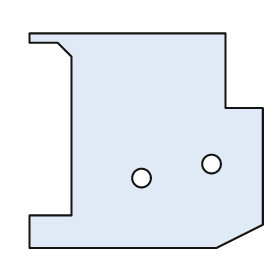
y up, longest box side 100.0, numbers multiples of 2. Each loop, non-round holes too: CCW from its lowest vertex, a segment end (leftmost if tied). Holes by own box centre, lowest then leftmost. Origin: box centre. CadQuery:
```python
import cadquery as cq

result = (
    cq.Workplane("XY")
    .moveTo(-50.0, -46.0)
    .lineTo(30.0, -46.0)
    .lineTo(50.0, -36.0)
    .lineTo(50.0, 14.0)
    .lineTo(34.0, 14.0)
    .lineTo(34.0, 46.0)
    .lineTo(-50.0, 46.0)
    .lineTo(-50.0, 42.0)
    .lineTo(-38.0, 42.0)
    .lineTo(-32.0, 36.0)
    .lineTo(-32.0, -32.0)
    .lineTo(-50.0, -32.0)
    .close()
    .moveTo(-2.0, -16.0)
    .circle(4.0)
    .moveTo(28.0, -10.0)
    .circle(4.0)
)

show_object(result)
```